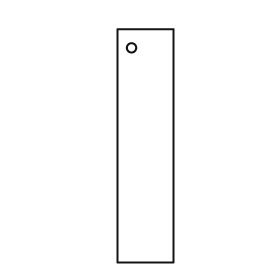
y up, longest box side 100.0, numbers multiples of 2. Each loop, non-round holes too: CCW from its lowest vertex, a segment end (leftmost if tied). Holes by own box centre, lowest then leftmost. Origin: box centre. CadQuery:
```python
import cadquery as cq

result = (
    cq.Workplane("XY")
    .moveTo(-12.0, -50.0)
    .lineTo(12.0, -50.0)
    .lineTo(12.0, 50.0)
    .lineTo(-12.0, 50.0)
    .close()
    .moveTo(-6.0, 42.0)
    .circle(2.0)
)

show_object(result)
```